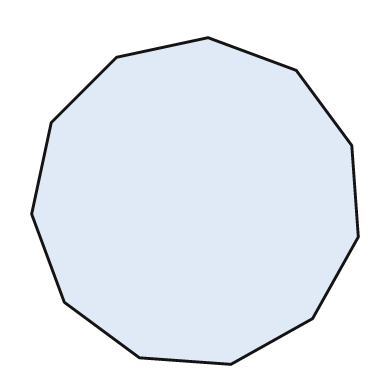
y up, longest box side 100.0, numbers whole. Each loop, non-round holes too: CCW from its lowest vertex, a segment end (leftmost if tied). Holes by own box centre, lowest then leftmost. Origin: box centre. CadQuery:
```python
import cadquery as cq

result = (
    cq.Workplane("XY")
    .moveTo(11.0, -50.0)
    .lineTo(36.0, -36.0)
    .lineTo(50.0, -11.0)
    .lineTo(48.0, 17.0)
    .lineTo(31.0, 40.0)
    .lineTo(4.0, 50.0)
    .lineTo(-24.0, 44.0)
    .lineTo(-44.0, 24.0)
    .lineTo(-50.0, -4.0)
    .lineTo(-40.0, -31.0)
    .lineTo(-17.0, -48.0)
    .close()
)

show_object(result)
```